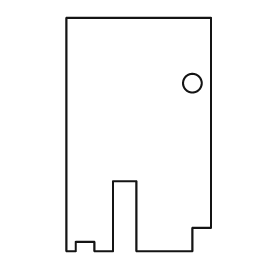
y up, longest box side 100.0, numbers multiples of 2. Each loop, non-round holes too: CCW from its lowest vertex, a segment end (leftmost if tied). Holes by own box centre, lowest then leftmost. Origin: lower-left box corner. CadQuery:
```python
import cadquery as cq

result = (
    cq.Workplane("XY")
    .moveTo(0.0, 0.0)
    .lineTo(4.0, 0.0)
    .lineTo(4.0, 4.0)
    .lineTo(12.0, 4.0)
    .lineTo(12.0, 0.0)
    .lineTo(20.0, 0.0)
    .lineTo(20.0, 30.0)
    .lineTo(30.0, 30.0)
    .lineTo(30.0, 0.0)
    .lineTo(54.0, 0.0)
    .lineTo(54.0, 10.0)
    .lineTo(62.0, 10.0)
    .lineTo(62.0, 100.0)
    .lineTo(0.0, 100.0)
    .close()
    .moveTo(54.0, 72.0)
    .circle(4.0)
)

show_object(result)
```